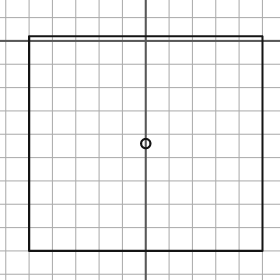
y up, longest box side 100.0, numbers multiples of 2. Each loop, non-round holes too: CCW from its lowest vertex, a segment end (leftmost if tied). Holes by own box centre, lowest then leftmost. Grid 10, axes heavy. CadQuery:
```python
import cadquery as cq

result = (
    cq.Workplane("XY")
    .moveTo(-50.0, -90.0)
    .lineTo(50.0, -90.0)
    .lineTo(50.0, 2.0)
    .lineTo(-50.0, 2.0)
    .close()
    .moveTo(0.0, -44.0)
    .circle(2.0)
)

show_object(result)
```